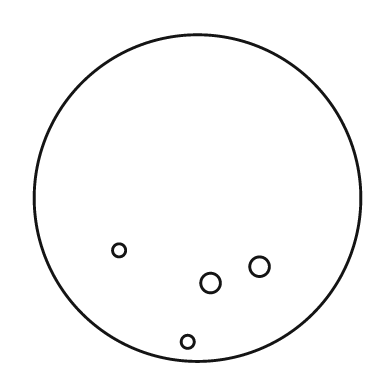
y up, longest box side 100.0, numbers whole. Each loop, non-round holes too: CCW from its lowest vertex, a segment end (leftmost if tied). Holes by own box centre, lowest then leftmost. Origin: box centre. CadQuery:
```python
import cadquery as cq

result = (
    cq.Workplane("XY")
    .moveTo(0.0, 0.0)
    .circle(50.0)
    .moveTo(-3.0, -44.0)
    .circle(2.0)
    .moveTo(4.0, -26.0)
    .circle(3.0)
    .moveTo(19.0, -21.0)
    .circle(3.0)
    .moveTo(-24.0, -16.0)
    .circle(2.0)
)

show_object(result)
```